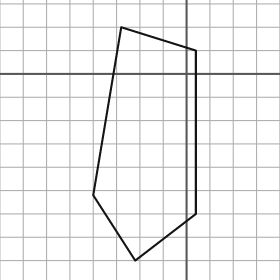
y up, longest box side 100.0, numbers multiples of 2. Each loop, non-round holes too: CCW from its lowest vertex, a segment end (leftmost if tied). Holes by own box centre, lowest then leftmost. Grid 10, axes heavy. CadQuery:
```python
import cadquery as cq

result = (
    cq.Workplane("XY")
    .moveTo(-22.0, -80.0)
    .lineTo(4.0, -60.0)
    .lineTo(4.0, 10.0)
    .lineTo(-28.0, 20.0)
    .lineTo(-40.0, -52.0)
    .close()
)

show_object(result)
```